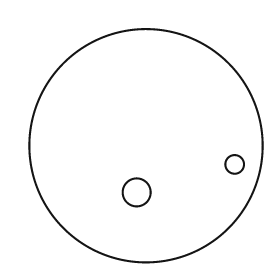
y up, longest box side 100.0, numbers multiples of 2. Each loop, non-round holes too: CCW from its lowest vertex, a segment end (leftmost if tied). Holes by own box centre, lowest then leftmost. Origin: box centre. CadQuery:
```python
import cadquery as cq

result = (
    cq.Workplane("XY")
    .moveTo(0.0, 0.0)
    .circle(50.0)
    .moveTo(-4.0, -20.0)
    .circle(6.0)
    .moveTo(38.0, -8.0)
    .circle(4.0)
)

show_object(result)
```